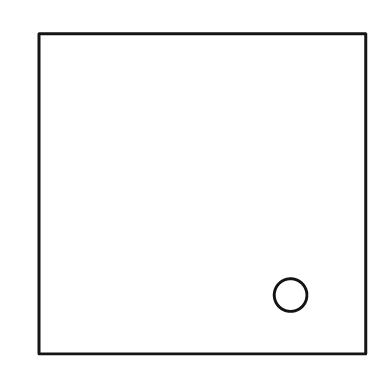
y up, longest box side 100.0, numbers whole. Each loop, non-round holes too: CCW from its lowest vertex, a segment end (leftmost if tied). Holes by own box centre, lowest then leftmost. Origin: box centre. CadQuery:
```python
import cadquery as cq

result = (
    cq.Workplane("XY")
    .moveTo(-50.0, -49.0)
    .lineTo(50.0, -49.0)
    .lineTo(50.0, 49.0)
    .lineTo(-50.0, 49.0)
    .close()
    .moveTo(27.0, -31.0)
    .circle(5.0)
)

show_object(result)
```